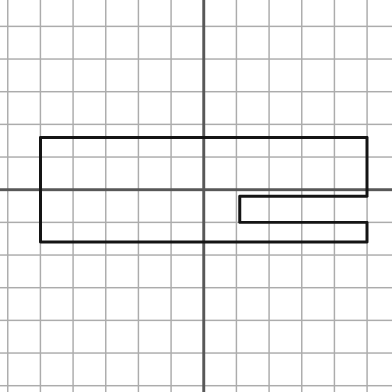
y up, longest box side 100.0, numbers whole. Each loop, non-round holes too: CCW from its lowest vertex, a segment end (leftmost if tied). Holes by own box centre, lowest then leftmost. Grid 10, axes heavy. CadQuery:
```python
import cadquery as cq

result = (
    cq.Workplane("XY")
    .moveTo(-50.0, -16.0)
    .lineTo(50.0, -16.0)
    .lineTo(50.0, -10.0)
    .lineTo(11.0, -10.0)
    .lineTo(11.0, -2.0)
    .lineTo(50.0, -2.0)
    .lineTo(50.0, 16.0)
    .lineTo(-50.0, 16.0)
    .close()
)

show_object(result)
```